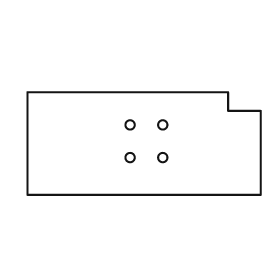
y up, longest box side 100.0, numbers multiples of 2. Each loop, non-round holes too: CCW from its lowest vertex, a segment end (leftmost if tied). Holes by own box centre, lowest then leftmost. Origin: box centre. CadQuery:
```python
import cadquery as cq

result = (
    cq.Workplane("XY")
    .moveTo(-50.0, -22.0)
    .lineTo(50.0, -22.0)
    .lineTo(50.0, 14.0)
    .lineTo(36.0, 14.0)
    .lineTo(36.0, 22.0)
    .lineTo(-50.0, 22.0)
    .close()
    .moveTo(-6.0, -6.0)
    .circle(2.0)
    .moveTo(8.0, -6.0)
    .circle(2.0)
    .moveTo(-6.0, 8.0)
    .circle(2.0)
    .moveTo(8.0, 8.0)
    .circle(2.0)
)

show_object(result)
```